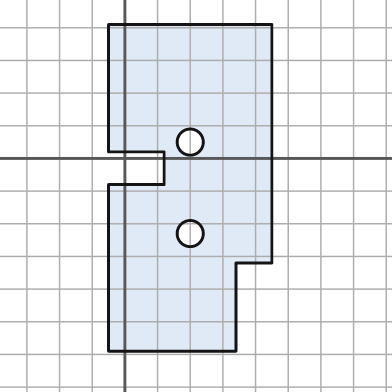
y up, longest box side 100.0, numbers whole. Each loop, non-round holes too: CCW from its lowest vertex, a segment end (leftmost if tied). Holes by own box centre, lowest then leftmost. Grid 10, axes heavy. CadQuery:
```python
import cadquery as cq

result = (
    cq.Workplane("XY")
    .moveTo(-5.0, -59.0)
    .lineTo(34.0, -59.0)
    .lineTo(34.0, -32.0)
    .lineTo(45.0, -32.0)
    .lineTo(45.0, 41.0)
    .lineTo(-5.0, 41.0)
    .lineTo(-5.0, 2.0)
    .lineTo(12.0, 2.0)
    .lineTo(12.0, -8.0)
    .lineTo(-5.0, -8.0)
    .close()
    .moveTo(20.0, -23.0)
    .circle(4.0)
    .moveTo(20.0, 5.0)
    .circle(4.0)
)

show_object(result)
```